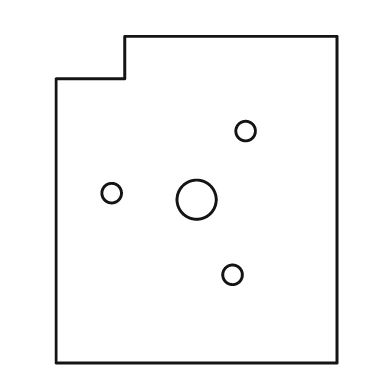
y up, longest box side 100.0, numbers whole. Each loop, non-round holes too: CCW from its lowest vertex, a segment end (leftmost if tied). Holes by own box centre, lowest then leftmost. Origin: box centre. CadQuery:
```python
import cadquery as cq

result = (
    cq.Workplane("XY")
    .moveTo(-43.0, -50.0)
    .lineTo(43.0, -50.0)
    .lineTo(43.0, 50.0)
    .lineTo(-22.0, 50.0)
    .lineTo(-22.0, 37.0)
    .lineTo(-43.0, 37.0)
    .close()
    .moveTo(11.0, -23.0)
    .circle(3.0)
    .moveTo(0.0, 0.0)
    .circle(6.0)
    .moveTo(-26.0, 2.0)
    .circle(3.0)
    .moveTo(15.0, 21.0)
    .circle(3.0)
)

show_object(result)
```